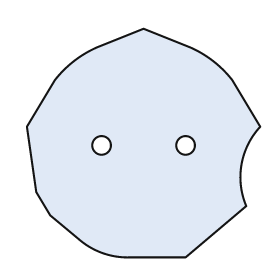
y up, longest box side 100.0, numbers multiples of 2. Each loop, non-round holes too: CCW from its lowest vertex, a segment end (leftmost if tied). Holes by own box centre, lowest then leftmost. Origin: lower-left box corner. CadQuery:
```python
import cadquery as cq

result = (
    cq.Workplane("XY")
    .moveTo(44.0, 0.0)
    .lineTo(68.0, 0.0)
    .lineTo(94.0, 22.0)
    .threePointArc((92.0, 40.0), (100.0, 56.0))
    .lineTo(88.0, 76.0)
    .threePointArc((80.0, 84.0), (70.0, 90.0))
    .lineTo(50.0, 98.0)
    .lineTo(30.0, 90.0)
    .threePointArc((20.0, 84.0), (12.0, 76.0))
    .lineTo(0.0, 56.0)
    .lineTo(4.0, 28.0)
    .lineTo(10.0, 18.0)
    .lineTo(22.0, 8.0)
    .threePointArc((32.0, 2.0), (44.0, 0.0))
    .close()
    .moveTo(32.0, 48.0)
    .circle(4.0)
    .moveTo(68.0, 48.0)
    .circle(4.0)
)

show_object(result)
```